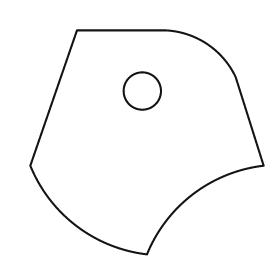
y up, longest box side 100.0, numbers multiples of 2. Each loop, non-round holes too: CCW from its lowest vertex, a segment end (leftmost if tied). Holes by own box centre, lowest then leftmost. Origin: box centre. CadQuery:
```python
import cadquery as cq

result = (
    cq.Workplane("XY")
    .moveTo(0.0, -48.0)
    .threePointArc((20.0, -22.0), (50.0, -10.0))
    .lineTo(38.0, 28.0)
    .threePointArc((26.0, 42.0), (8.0, 48.0))
    .lineTo(-30.0, 48.0)
    .lineTo(-50.0, -10.0)
    .threePointArc((-30.0, -36.0), (0.0, -48.0))
    .close()
    .moveTo(-2.0, 22.0)
    .circle(8.0)
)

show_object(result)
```